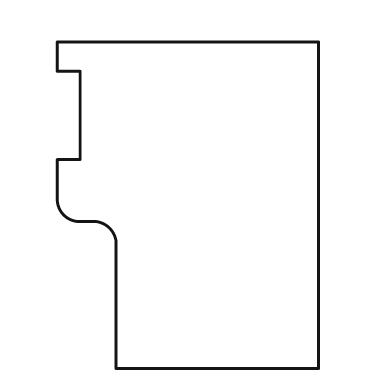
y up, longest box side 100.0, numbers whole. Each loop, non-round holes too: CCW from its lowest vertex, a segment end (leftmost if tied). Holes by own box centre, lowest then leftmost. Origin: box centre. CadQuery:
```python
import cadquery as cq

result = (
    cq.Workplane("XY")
    .moveTo(-22.0, -50.0)
    .lineTo(40.0, -50.0)
    .lineTo(40.0, 50.0)
    .lineTo(-40.0, 50.0)
    .lineTo(-40.0, 41.0)
    .lineTo(-33.0, 41.0)
    .lineTo(-33.0, 14.0)
    .lineTo(-40.0, 14.0)
    .lineTo(-40.0, 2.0)
    .threePointArc((-38.0, -3.0), (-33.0, -5.0))
    .lineTo(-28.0, -5.0)
    .threePointArc((-24.0, -7.0), (-22.0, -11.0))
    .close()
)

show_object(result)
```